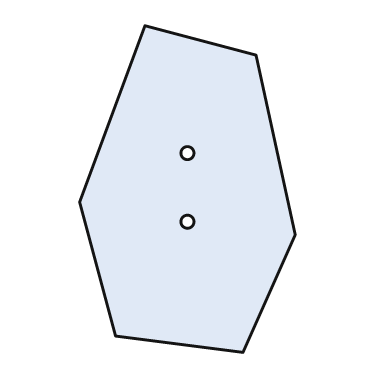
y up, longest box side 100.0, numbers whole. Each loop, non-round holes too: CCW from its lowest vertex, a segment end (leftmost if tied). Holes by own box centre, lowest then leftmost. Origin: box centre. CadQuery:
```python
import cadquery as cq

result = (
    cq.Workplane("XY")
    .moveTo(17.0, -50.0)
    .lineTo(33.0, -14.0)
    .lineTo(21.0, 41.0)
    .lineTo(-13.0, 50.0)
    .lineTo(-33.0, -4.0)
    .lineTo(-22.0, -45.0)
    .close()
    .moveTo(0.0, -10.0)
    .circle(2.0)
    .moveTo(0.0, 11.0)
    .circle(2.0)
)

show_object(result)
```